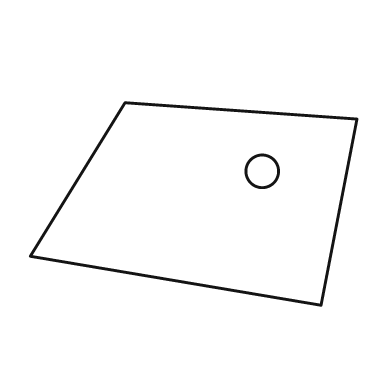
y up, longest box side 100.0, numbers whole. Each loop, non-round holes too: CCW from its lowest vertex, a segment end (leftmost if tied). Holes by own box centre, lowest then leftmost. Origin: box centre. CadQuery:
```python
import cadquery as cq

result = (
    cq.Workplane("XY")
    .moveTo(39.0, -31.0)
    .lineTo(50.0, 26.0)
    .lineTo(-21.0, 31.0)
    .lineTo(-50.0, -16.0)
    .close()
    .moveTo(21.0, 10.0)
    .circle(5.0)
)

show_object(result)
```